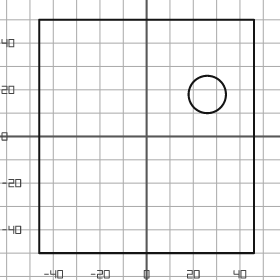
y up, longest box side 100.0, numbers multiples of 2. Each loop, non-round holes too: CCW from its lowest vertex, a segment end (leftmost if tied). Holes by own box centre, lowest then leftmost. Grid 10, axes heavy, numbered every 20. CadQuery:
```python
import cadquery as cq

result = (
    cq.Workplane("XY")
    .moveTo(-46.0, -50.0)
    .lineTo(46.0, -50.0)
    .lineTo(46.0, 50.0)
    .lineTo(-46.0, 50.0)
    .close()
    .moveTo(26.0, 18.0)
    .circle(8.0)
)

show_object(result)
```